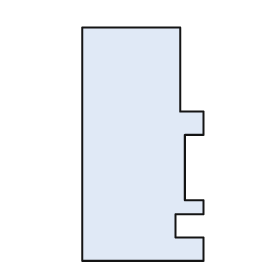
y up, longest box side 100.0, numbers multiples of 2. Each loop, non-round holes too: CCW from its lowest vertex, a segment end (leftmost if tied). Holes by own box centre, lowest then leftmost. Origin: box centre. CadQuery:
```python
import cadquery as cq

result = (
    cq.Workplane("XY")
    .moveTo(-26.0, -50.0)
    .lineTo(26.0, -50.0)
    .lineTo(26.0, -40.0)
    .lineTo(14.0, -40.0)
    .lineTo(14.0, -30.0)
    .lineTo(26.0, -30.0)
    .lineTo(26.0, -24.0)
    .lineTo(18.0, -24.0)
    .lineTo(18.0, 4.0)
    .lineTo(26.0, 4.0)
    .lineTo(26.0, 14.0)
    .lineTo(16.0, 14.0)
    .lineTo(16.0, 50.0)
    .lineTo(-26.0, 50.0)
    .close()
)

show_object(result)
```